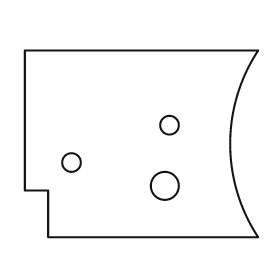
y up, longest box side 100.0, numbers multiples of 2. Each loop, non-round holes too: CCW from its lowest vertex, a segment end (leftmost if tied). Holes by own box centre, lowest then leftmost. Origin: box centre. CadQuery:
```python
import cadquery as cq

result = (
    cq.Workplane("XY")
    .moveTo(-40.0, -40.0)
    .lineTo(50.0, -40.0)
    .threePointArc((38.0, 0.0), (50.0, 40.0))
    .lineTo(-50.0, 40.0)
    .lineTo(-50.0, -20.0)
    .lineTo(-40.0, -20.0)
    .close()
    .moveTo(10.0, -18.0)
    .circle(6.0)
    .moveTo(-30.0, -8.0)
    .circle(4.0)
    .moveTo(12.0, 8.0)
    .circle(4.0)
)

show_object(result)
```